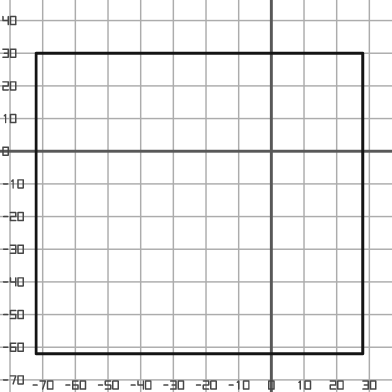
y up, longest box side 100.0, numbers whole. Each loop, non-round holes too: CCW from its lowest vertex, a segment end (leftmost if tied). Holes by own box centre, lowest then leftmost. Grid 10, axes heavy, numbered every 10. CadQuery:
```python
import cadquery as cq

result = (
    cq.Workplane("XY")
    .moveTo(-72.0, -62.0)
    .lineTo(28.0, -62.0)
    .lineTo(28.0, 30.0)
    .lineTo(-72.0, 30.0)
    .close()
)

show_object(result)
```